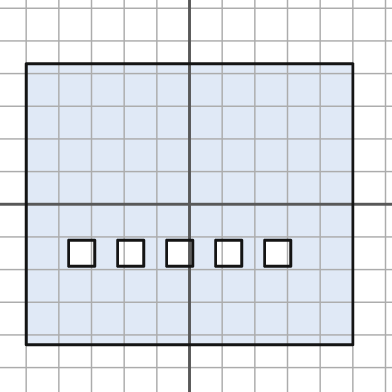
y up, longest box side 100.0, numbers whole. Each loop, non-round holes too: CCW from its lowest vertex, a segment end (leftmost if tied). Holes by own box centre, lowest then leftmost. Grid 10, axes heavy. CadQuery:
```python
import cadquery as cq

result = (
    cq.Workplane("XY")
    .moveTo(-50.0, -43.0)
    .lineTo(50.0, -43.0)
    .lineTo(50.0, 43.0)
    .lineTo(-50.0, 43.0)
    .close()
    .moveTo(-37.0, -19.0)
    .lineTo(-29.0, -19.0)
    .lineTo(-29.0, -11.0)
    .lineTo(-37.0, -11.0)
    .close()
    .moveTo(-22.0, -19.0)
    .lineTo(-14.0, -19.0)
    .lineTo(-14.0, -11.0)
    .lineTo(-22.0, -11.0)
    .close()
    .moveTo(-7.0, -19.0)
    .lineTo(1.0, -19.0)
    .lineTo(1.0, -11.0)
    .lineTo(-7.0, -11.0)
    .close()
    .moveTo(8.0, -19.0)
    .lineTo(16.0, -19.0)
    .lineTo(16.0, -11.0)
    .lineTo(8.0, -11.0)
    .close()
    .moveTo(23.0, -19.0)
    .lineTo(31.0, -19.0)
    .lineTo(31.0, -11.0)
    .lineTo(23.0, -11.0)
    .close()
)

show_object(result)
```